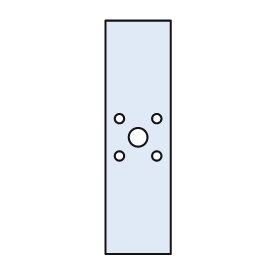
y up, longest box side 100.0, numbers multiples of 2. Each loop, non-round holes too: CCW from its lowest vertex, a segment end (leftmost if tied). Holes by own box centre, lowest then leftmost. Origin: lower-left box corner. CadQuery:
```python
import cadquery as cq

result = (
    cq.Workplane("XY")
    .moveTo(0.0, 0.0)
    .lineTo(28.0, 0.0)
    .lineTo(28.0, 100.0)
    .lineTo(0.0, 100.0)
    .close()
    .moveTo(6.0, 42.0)
    .circle(2.0)
    .moveTo(22.0, 42.0)
    .circle(2.0)
    .moveTo(14.0, 50.0)
    .circle(4.0)
    .moveTo(6.0, 58.0)
    .circle(2.0)
    .moveTo(22.0, 58.0)
    .circle(2.0)
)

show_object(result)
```